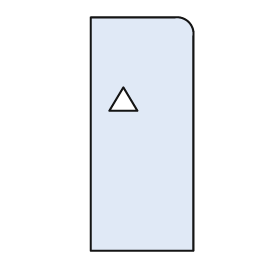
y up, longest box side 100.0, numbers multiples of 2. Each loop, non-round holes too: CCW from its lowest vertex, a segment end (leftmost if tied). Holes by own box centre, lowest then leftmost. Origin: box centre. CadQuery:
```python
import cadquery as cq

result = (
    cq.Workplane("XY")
    .moveTo(-22.0, -50.0)
    .lineTo(22.0, -50.0)
    .lineTo(22.0, 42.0)
    .threePointArc((20.0, 48.0), (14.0, 50.0))
    .lineTo(-22.0, 50.0)
    .close()
    .moveTo(-14.0, 10.0)
    .lineTo(-2.0, 10.0)
    .lineTo(-8.0, 20.0)
    .close()
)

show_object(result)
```